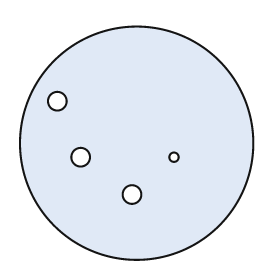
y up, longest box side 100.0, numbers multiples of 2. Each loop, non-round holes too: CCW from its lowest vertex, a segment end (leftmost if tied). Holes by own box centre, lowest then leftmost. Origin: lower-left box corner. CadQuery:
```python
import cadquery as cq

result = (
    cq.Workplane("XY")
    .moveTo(50.0, 50.0)
    .circle(50.0)
    .moveTo(48.0, 28.0)
    .circle(4.0)
    .moveTo(26.0, 44.0)
    .circle(4.0)
    .moveTo(66.0, 44.0)
    .circle(2.0)
    .moveTo(16.0, 68.0)
    .circle(4.0)
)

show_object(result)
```